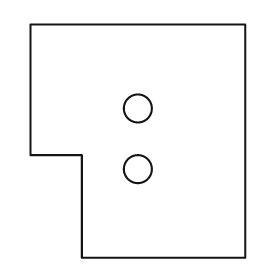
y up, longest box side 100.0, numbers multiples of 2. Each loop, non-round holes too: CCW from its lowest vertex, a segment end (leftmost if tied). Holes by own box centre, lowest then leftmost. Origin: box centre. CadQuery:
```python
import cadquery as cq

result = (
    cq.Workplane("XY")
    .moveTo(-24.0, -50.0)
    .lineTo(46.0, -50.0)
    .lineTo(46.0, 50.0)
    .lineTo(-46.0, 50.0)
    .lineTo(-46.0, -6.0)
    .lineTo(-24.0, -6.0)
    .close()
    .moveTo(0.0, -12.0)
    .circle(6.0)
    .moveTo(0.0, 14.0)
    .circle(6.0)
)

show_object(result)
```